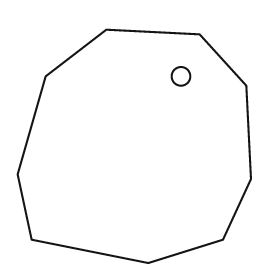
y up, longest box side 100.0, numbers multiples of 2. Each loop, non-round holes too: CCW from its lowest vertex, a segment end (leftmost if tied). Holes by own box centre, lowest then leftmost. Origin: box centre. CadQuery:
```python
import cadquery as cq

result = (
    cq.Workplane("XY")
    .moveTo(6.0, -50.0)
    .lineTo(38.0, -40.0)
    .lineTo(50.0, -14.0)
    .lineTo(48.0, 26.0)
    .lineTo(28.0, 48.0)
    .lineTo(-12.0, 50.0)
    .lineTo(-38.0, 30.0)
    .lineTo(-50.0, -12.0)
    .lineTo(-44.0, -40.0)
    .close()
    .moveTo(20.0, 30.0)
    .circle(4.0)
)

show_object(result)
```